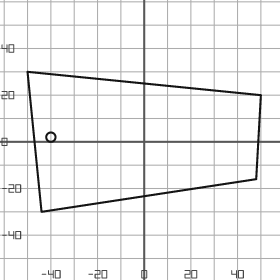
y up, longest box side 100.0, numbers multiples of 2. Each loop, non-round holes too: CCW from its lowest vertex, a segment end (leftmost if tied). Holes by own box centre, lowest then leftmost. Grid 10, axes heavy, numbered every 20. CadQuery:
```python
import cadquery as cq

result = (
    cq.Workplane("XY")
    .moveTo(-44.0, -30.0)
    .lineTo(48.0, -16.0)
    .lineTo(50.0, 20.0)
    .lineTo(-50.0, 30.0)
    .close()
    .moveTo(-40.0, 2.0)
    .circle(2.0)
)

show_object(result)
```